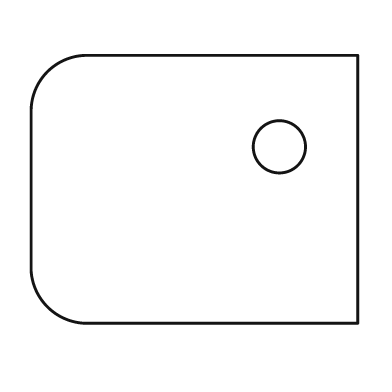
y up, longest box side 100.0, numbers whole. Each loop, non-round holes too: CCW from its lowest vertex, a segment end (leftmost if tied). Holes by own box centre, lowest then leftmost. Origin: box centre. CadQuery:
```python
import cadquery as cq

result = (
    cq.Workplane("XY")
    .moveTo(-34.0, -41.0)
    .lineTo(50.0, -41.0)
    .lineTo(50.0, 41.0)
    .lineTo(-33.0, 41.0)
    .threePointArc((-45.0, 36.0), (-50.0, 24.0))
    .lineTo(-50.0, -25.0)
    .threePointArc((-45.0, -36.0), (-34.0, -41.0))
    .close()
    .moveTo(26.0, 13.0)
    .circle(8.0)
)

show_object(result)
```